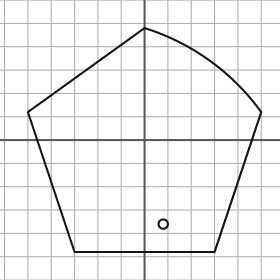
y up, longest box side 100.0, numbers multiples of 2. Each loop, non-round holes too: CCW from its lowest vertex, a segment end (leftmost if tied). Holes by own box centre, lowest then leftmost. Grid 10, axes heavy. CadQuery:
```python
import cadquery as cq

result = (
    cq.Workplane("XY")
    .moveTo(-30.0, -48.0)
    .lineTo(30.0, -48.0)
    .lineTo(50.0, 12.0)
    .threePointArc((28.0, 34.0), (0.0, 48.0))
    .lineTo(-50.0, 12.0)
    .close()
    .moveTo(8.0, -36.0)
    .circle(2.0)
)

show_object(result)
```